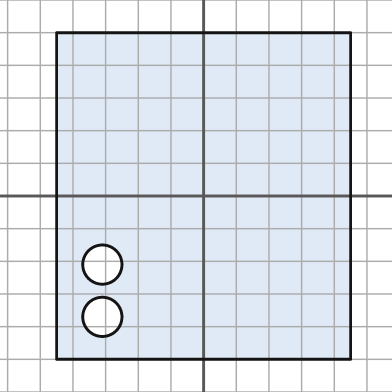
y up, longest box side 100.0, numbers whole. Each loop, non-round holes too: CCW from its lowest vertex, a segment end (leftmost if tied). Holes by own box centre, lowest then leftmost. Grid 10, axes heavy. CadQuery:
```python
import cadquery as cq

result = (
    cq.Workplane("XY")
    .moveTo(-45.0, -50.0)
    .lineTo(45.0, -50.0)
    .lineTo(45.0, 50.0)
    .lineTo(-45.0, 50.0)
    .close()
    .moveTo(-31.0, -37.0)
    .circle(6.0)
    .moveTo(-31.0, -21.0)
    .circle(6.0)
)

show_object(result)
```